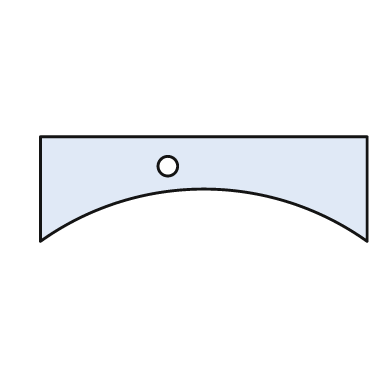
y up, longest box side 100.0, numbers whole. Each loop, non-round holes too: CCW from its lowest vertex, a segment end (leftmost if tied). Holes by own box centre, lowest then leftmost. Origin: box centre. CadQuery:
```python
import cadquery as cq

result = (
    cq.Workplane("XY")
    .moveTo(-50.0, -16.0)
    .threePointArc((0.0, 0.0), (50.0, -16.0))
    .lineTo(50.0, 16.0)
    .lineTo(-50.0, 16.0)
    .close()
    .moveTo(-11.0, 7.0)
    .circle(3.0)
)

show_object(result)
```